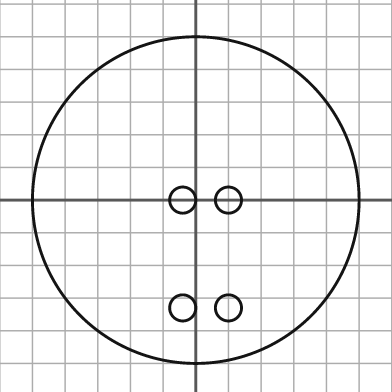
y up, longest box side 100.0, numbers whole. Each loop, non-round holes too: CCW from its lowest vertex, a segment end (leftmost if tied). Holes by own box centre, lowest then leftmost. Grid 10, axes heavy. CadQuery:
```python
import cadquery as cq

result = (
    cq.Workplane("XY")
    .moveTo(0.0, 0.0)
    .circle(50.0)
    .moveTo(-4.0, -33.0)
    .circle(4.0)
    .moveTo(10.0, -33.0)
    .circle(4.0)
    .moveTo(-4.0, 0.0)
    .circle(4.0)
    .moveTo(10.0, 0.0)
    .circle(4.0)
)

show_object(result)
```